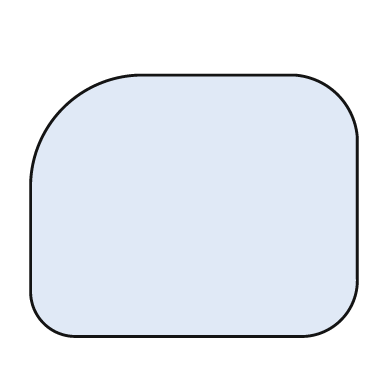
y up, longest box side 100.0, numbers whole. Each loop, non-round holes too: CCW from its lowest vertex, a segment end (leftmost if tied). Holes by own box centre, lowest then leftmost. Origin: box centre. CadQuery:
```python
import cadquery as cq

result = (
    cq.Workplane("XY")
    .moveTo(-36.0, -40.0)
    .lineTo(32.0, -40.0)
    .threePointArc((45.0, -35.0), (50.0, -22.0))
    .lineTo(50.0, 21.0)
    .threePointArc((44.0, 34.0), (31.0, 40.0))
    .lineTo(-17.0, 40.0)
    .threePointArc((-40.0, 30.0), (-50.0, 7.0))
    .lineTo(-50.0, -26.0)
    .threePointArc((-46.0, -36.0), (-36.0, -40.0))
    .close()
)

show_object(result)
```